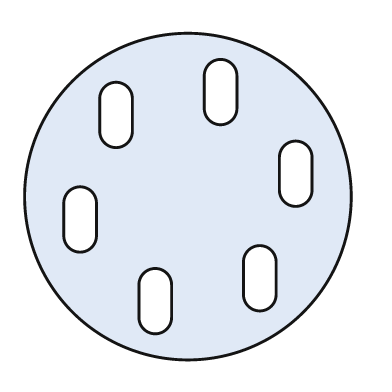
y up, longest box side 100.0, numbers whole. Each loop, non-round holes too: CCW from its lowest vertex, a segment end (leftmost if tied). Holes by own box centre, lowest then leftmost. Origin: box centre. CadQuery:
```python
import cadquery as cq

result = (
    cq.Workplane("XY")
    .moveTo(0.0, 0.0)
    .circle(50.0)
    .moveTo(-15.0, -37.0)
    .threePointArc((-10.0, -42.0), (-5.0, -37.0))
    .lineTo(-5.0, -27.0)
    .threePointArc((-10.0, -22.0), (-15.0, -27.0))
    .close()
    .moveTo(17.0, -30.0)
    .threePointArc((22.0, -35.0), (27.0, -30.0))
    .lineTo(27.0, -20.0)
    .threePointArc((22.0, -15.0), (17.0, -20.0))
    .close()
    .moveTo(-38.0, -12.0)
    .threePointArc((-33.0, -17.0), (-28.0, -12.0))
    .lineTo(-28.0, -2.0)
    .threePointArc((-33.0, 3.0), (-38.0, -2.0))
    .close()
    .moveTo(28.0, 2.0)
    .threePointArc((33.0, -3.0), (38.0, 2.0))
    .lineTo(38.0, 12.0)
    .threePointArc((33.0, 17.0), (28.0, 12.0))
    .close()
    .moveTo(-27.0, 20.0)
    .threePointArc((-22.0, 15.0), (-17.0, 20.0))
    .lineTo(-17.0, 30.0)
    .threePointArc((-22.0, 35.0), (-27.0, 30.0))
    .close()
    .moveTo(5.0, 27.0)
    .threePointArc((10.0, 22.0), (15.0, 27.0))
    .lineTo(15.0, 37.0)
    .threePointArc((10.0, 42.0), (5.0, 37.0))
    .close()
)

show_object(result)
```